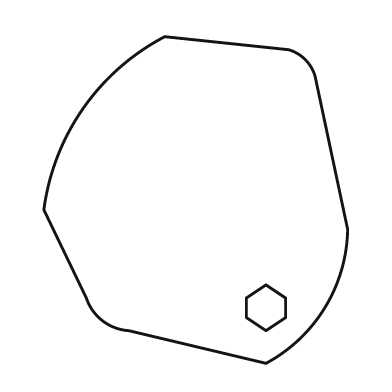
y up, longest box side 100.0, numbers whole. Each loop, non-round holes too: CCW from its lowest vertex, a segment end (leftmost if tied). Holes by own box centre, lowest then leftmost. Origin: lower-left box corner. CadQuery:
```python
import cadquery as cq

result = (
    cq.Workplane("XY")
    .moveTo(68.0, 0.0)
    .threePointArc((86.0, 17.0), (93.0, 41.0))
    .lineTo(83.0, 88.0)
    .threePointArc((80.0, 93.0), (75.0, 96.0))
    .lineTo(37.0, 100.0)
    .threePointArc((12.0, 78.0), (0.0, 47.0))
    .lineTo(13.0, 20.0)
    .threePointArc((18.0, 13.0), (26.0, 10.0))
    .close()
    .moveTo(68.0, 10.0)
    .lineTo(74.0, 14.0)
    .lineTo(74.0, 20.0)
    .lineTo(68.0, 24.0)
    .lineTo(62.0, 20.0)
    .lineTo(62.0, 14.0)
    .close()
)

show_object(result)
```